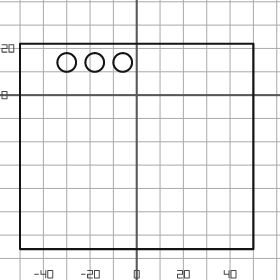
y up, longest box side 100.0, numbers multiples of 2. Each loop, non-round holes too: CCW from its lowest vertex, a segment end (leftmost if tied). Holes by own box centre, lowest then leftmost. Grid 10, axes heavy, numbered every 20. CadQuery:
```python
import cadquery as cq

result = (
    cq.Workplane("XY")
    .moveTo(-50.0, -66.0)
    .lineTo(50.0, -66.0)
    .lineTo(50.0, 22.0)
    .lineTo(-50.0, 22.0)
    .close()
    .moveTo(-30.0, 14.0)
    .circle(4.0)
    .moveTo(-18.0, 14.0)
    .circle(4.0)
    .moveTo(-6.0, 14.0)
    .circle(4.0)
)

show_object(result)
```